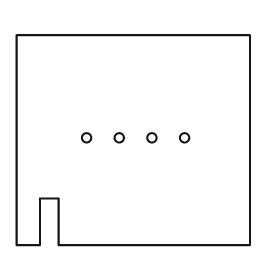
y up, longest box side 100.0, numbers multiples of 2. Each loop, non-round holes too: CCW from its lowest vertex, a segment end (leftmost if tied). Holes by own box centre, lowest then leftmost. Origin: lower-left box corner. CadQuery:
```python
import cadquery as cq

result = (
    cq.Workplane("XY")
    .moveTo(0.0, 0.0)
    .lineTo(10.0, 0.0)
    .lineTo(10.0, 20.0)
    .lineTo(18.0, 20.0)
    .lineTo(18.0, 0.0)
    .lineTo(100.0, 0.0)
    .lineTo(100.0, 90.0)
    .lineTo(0.0, 90.0)
    .close()
    .moveTo(30.0, 46.0)
    .circle(2.0)
    .moveTo(44.0, 46.0)
    .circle(2.0)
    .moveTo(58.0, 46.0)
    .circle(2.0)
    .moveTo(72.0, 46.0)
    .circle(2.0)
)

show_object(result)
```